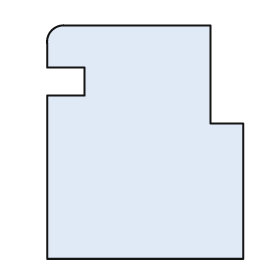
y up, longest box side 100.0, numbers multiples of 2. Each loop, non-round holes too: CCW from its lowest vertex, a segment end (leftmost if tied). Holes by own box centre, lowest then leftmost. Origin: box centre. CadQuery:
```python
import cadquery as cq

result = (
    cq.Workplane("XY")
    .moveTo(-42.0, -50.0)
    .lineTo(42.0, -50.0)
    .lineTo(42.0, 8.0)
    .lineTo(28.0, 8.0)
    .lineTo(28.0, 50.0)
    .lineTo(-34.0, 50.0)
    .threePointArc((-40.0, 48.0), (-42.0, 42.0))
    .lineTo(-42.0, 32.0)
    .lineTo(-26.0, 32.0)
    .lineTo(-26.0, 20.0)
    .lineTo(-42.0, 20.0)
    .close()
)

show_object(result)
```